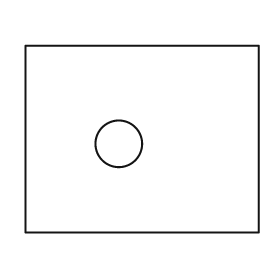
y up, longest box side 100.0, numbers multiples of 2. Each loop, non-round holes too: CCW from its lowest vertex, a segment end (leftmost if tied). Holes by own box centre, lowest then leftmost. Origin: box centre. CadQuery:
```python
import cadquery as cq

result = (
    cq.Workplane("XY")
    .moveTo(-50.0, -40.0)
    .lineTo(50.0, -40.0)
    .lineTo(50.0, 40.0)
    .lineTo(-50.0, 40.0)
    .close()
    .moveTo(-10.0, -2.0)
    .circle(10.0)
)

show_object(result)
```